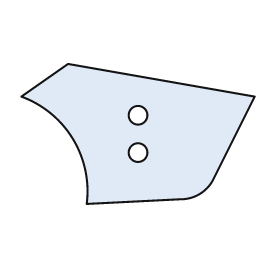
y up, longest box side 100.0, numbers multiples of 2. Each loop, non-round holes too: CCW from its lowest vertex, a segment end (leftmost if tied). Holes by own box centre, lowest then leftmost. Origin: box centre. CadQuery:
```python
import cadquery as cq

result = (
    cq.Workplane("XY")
    .moveTo(-22.0, -30.0)
    .lineTo(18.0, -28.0)
    .threePointArc((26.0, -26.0), (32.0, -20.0))
    .lineTo(50.0, 16.0)
    .lineTo(-30.0, 30.0)
    .lineTo(-50.0, 16.0)
    .threePointArc((-28.0, -2.0), (-22.0, -30.0))
    .close()
    .moveTo(0.0, -8.0)
    .circle(4.0)
    .moveTo(0.0, 8.0)
    .circle(4.0)
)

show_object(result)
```